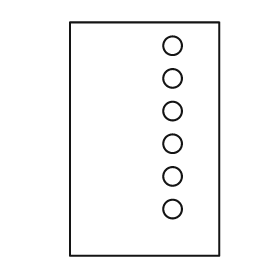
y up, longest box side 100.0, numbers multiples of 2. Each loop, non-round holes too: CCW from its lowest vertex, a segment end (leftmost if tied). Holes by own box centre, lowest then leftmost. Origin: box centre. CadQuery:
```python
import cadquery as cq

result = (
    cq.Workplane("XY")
    .moveTo(-32.0, -50.0)
    .lineTo(32.0, -50.0)
    .lineTo(32.0, 50.0)
    .lineTo(-32.0, 50.0)
    .close()
    .moveTo(12.0, -30.0)
    .circle(4.0)
    .moveTo(12.0, -16.0)
    .circle(4.0)
    .moveTo(12.0, -2.0)
    .circle(4.0)
    .moveTo(12.0, 12.0)
    .circle(4.0)
    .moveTo(12.0, 26.0)
    .circle(4.0)
    .moveTo(12.0, 40.0)
    .circle(4.0)
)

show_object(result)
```